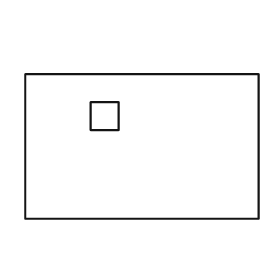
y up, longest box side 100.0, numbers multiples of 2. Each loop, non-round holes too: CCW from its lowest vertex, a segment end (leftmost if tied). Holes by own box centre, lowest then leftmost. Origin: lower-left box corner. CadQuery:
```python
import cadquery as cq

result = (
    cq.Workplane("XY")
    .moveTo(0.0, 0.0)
    .lineTo(100.0, 0.0)
    .lineTo(100.0, 62.0)
    .lineTo(0.0, 62.0)
    .close()
    .moveTo(28.0, 38.0)
    .lineTo(40.0, 38.0)
    .lineTo(40.0, 50.0)
    .lineTo(28.0, 50.0)
    .close()
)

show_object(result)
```